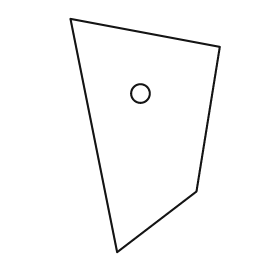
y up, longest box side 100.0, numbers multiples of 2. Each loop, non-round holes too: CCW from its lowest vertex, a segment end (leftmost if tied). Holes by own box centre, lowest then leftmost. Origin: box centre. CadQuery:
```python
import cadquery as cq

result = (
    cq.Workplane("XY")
    .moveTo(-12.0, -50.0)
    .lineTo(22.0, -24.0)
    .lineTo(32.0, 38.0)
    .lineTo(-32.0, 50.0)
    .close()
    .moveTo(-2.0, 18.0)
    .circle(4.0)
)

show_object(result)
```